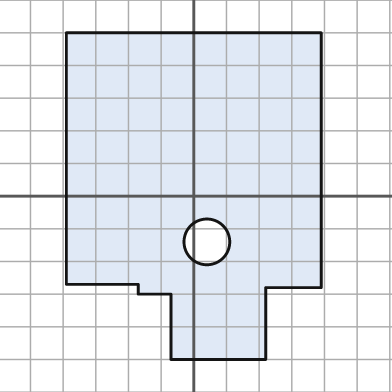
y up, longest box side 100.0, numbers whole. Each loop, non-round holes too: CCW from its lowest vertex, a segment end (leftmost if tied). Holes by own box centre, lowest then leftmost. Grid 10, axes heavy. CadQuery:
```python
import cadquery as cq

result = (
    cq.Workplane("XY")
    .moveTo(-7.0, -50.0)
    .lineTo(22.0, -50.0)
    .lineTo(22.0, -28.0)
    .lineTo(39.0, -28.0)
    .lineTo(39.0, 50.0)
    .lineTo(-39.0, 50.0)
    .lineTo(-39.0, -27.0)
    .lineTo(-17.0, -27.0)
    .lineTo(-17.0, -30.0)
    .lineTo(-7.0, -30.0)
    .close()
    .moveTo(4.0, -14.0)
    .circle(7.0)
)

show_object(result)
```